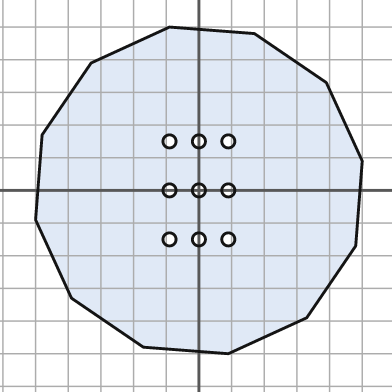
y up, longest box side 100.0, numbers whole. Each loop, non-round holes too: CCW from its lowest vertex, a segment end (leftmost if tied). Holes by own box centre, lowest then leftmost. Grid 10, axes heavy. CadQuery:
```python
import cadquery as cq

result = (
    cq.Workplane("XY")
    .moveTo(9.0, -50.0)
    .lineTo(33.0, -39.0)
    .lineTo(48.0, -17.0)
    .lineTo(50.0, 9.0)
    .lineTo(39.0, 33.0)
    .lineTo(17.0, 48.0)
    .lineTo(-9.0, 50.0)
    .lineTo(-33.0, 39.0)
    .lineTo(-48.0, 17.0)
    .lineTo(-50.0, -9.0)
    .lineTo(-39.0, -33.0)
    .lineTo(-17.0, -48.0)
    .close()
    .moveTo(-9.0, -15.0)
    .circle(2.0)
    .moveTo(0.0, -15.0)
    .circle(2.0)
    .moveTo(9.0, -15.0)
    .circle(2.0)
    .moveTo(-9.0, 0.0)
    .circle(2.0)
    .moveTo(0.0, 0.0)
    .circle(2.0)
    .moveTo(9.0, 0.0)
    .circle(2.0)
    .moveTo(-9.0, 15.0)
    .circle(2.0)
    .moveTo(0.0, 15.0)
    .circle(2.0)
    .moveTo(9.0, 15.0)
    .circle(2.0)
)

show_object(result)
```